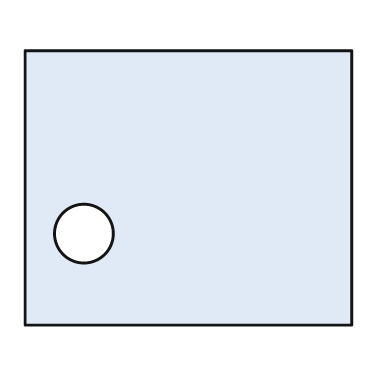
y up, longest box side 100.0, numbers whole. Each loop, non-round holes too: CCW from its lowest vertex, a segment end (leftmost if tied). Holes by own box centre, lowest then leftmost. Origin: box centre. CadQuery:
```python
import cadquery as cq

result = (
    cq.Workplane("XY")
    .moveTo(-50.0, -42.0)
    .lineTo(50.0, -42.0)
    .lineTo(50.0, 42.0)
    .lineTo(-50.0, 42.0)
    .close()
    .moveTo(-32.0, -14.0)
    .circle(9.0)
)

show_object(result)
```